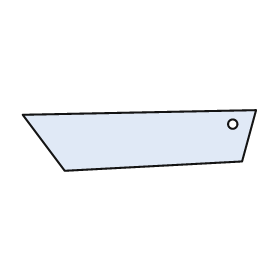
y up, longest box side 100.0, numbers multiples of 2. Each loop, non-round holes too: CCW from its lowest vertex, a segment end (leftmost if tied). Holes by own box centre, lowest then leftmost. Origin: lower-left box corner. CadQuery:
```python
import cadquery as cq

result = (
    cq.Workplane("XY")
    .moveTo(18.0, 0.0)
    .lineTo(94.0, 4.0)
    .lineTo(100.0, 26.0)
    .lineTo(0.0, 24.0)
    .close()
    .moveTo(90.0, 20.0)
    .circle(2.0)
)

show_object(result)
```